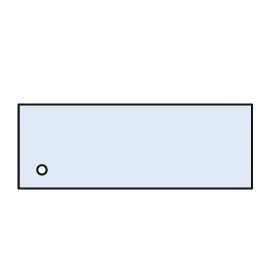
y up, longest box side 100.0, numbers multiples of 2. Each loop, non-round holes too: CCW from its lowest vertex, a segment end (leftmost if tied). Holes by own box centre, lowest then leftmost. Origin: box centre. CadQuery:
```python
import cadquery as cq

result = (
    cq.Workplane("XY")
    .moveTo(-50.0, -18.0)
    .lineTo(50.0, -18.0)
    .lineTo(50.0, 18.0)
    .lineTo(-50.0, 18.0)
    .close()
    .moveTo(-40.0, -10.0)
    .circle(2.0)
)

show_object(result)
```